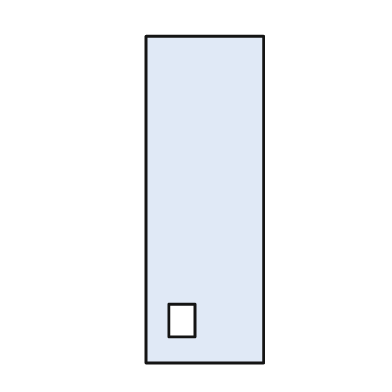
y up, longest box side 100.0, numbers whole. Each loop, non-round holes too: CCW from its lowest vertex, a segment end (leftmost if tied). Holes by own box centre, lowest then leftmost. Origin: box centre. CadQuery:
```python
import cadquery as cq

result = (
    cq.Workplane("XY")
    .moveTo(-18.0, -50.0)
    .lineTo(18.0, -50.0)
    .lineTo(18.0, 50.0)
    .lineTo(-18.0, 50.0)
    .close()
    .moveTo(-11.0, -42.0)
    .lineTo(-3.0, -42.0)
    .lineTo(-3.0, -32.0)
    .lineTo(-11.0, -32.0)
    .close()
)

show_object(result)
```